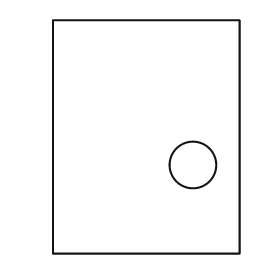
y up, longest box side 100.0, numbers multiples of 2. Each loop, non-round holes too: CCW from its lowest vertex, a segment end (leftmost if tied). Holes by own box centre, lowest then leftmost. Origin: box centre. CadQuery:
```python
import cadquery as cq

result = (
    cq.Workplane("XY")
    .moveTo(-40.0, -50.0)
    .lineTo(40.0, -50.0)
    .lineTo(40.0, 50.0)
    .lineTo(-40.0, 50.0)
    .close()
    .moveTo(20.0, -12.0)
    .circle(10.0)
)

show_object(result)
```